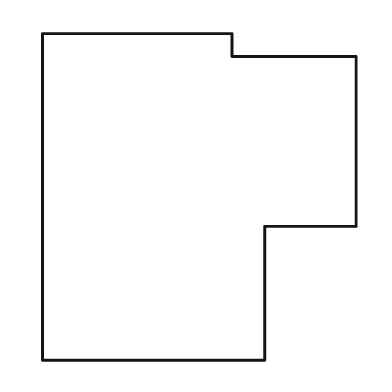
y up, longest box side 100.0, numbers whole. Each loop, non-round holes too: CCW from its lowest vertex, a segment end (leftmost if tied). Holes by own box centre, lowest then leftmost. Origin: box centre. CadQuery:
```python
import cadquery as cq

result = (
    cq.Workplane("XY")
    .moveTo(-48.0, -50.0)
    .lineTo(20.0, -50.0)
    .lineTo(20.0, -9.0)
    .lineTo(48.0, -9.0)
    .lineTo(48.0, 43.0)
    .lineTo(10.0, 43.0)
    .lineTo(10.0, 50.0)
    .lineTo(-48.0, 50.0)
    .close()
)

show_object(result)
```